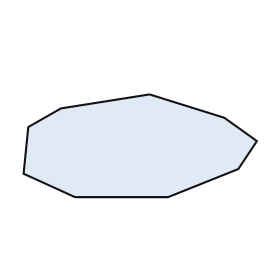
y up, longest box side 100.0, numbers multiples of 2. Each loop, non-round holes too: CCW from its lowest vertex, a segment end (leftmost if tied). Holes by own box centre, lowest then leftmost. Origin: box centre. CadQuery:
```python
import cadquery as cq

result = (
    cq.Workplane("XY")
    .moveTo(-28.0, -22.0)
    .lineTo(12.0, -22.0)
    .lineTo(42.0, -10.0)
    .lineTo(50.0, 2.0)
    .lineTo(36.0, 12.0)
    .lineTo(4.0, 22.0)
    .lineTo(-34.0, 16.0)
    .lineTo(-48.0, 8.0)
    .lineTo(-50.0, -12.0)
    .close()
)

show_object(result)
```